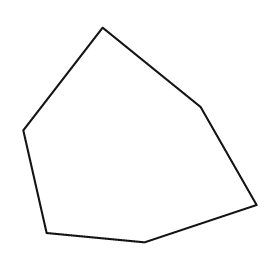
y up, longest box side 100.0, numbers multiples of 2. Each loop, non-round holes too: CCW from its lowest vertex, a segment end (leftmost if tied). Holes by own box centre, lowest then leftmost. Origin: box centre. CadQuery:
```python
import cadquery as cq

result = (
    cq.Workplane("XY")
    .moveTo(2.0, -46.0)
    .lineTo(50.0, -30.0)
    .lineTo(26.0, 12.0)
    .lineTo(-16.0, 46.0)
    .lineTo(-50.0, 2.0)
    .lineTo(-40.0, -42.0)
    .close()
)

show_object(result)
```